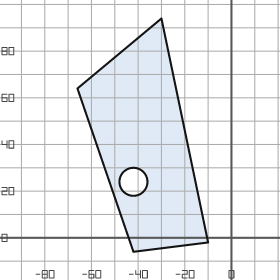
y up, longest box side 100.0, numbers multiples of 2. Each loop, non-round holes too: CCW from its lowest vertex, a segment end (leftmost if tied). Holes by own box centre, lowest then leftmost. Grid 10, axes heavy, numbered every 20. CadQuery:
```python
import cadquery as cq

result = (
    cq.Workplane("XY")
    .moveTo(-42.0, -6.0)
    .lineTo(-10.0, -2.0)
    .lineTo(-30.0, 94.0)
    .lineTo(-66.0, 64.0)
    .close()
    .moveTo(-42.0, 24.0)
    .circle(6.0)
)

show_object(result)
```